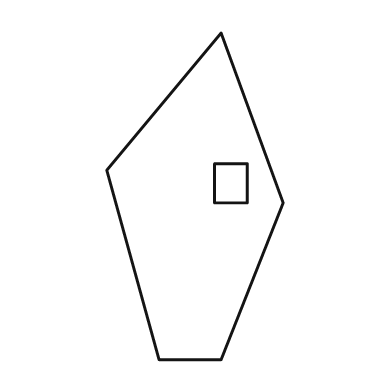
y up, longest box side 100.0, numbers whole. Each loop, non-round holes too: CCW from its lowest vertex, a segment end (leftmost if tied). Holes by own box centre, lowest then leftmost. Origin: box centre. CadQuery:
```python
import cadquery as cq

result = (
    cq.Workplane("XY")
    .moveTo(-11.0, -50.0)
    .lineTo(8.0, -50.0)
    .lineTo(27.0, -2.0)
    .lineTo(8.0, 50.0)
    .lineTo(-27.0, 8.0)
    .close()
    .moveTo(6.0, -2.0)
    .lineTo(16.0, -2.0)
    .lineTo(16.0, 10.0)
    .lineTo(6.0, 10.0)
    .close()
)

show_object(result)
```